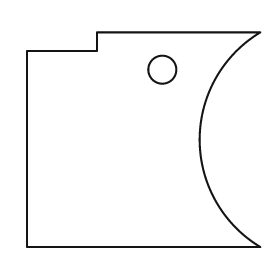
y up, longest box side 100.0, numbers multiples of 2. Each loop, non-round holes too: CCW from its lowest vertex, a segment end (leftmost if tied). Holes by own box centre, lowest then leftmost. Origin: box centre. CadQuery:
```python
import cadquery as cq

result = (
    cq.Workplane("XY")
    .moveTo(-50.0, -46.0)
    .lineTo(50.0, -46.0)
    .threePointArc((24.0, 0.0), (50.0, 46.0))
    .lineTo(-20.0, 46.0)
    .lineTo(-20.0, 38.0)
    .lineTo(-50.0, 38.0)
    .close()
    .moveTo(8.0, 30.0)
    .circle(6.0)
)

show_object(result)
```